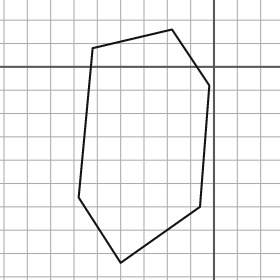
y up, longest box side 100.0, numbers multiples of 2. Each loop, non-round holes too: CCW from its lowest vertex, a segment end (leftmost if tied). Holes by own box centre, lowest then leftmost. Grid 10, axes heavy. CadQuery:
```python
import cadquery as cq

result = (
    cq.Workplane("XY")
    .moveTo(-40.0, -84.0)
    .lineTo(-6.0, -60.0)
    .lineTo(-2.0, -8.0)
    .lineTo(-18.0, 16.0)
    .lineTo(-52.0, 8.0)
    .lineTo(-58.0, -56.0)
    .close()
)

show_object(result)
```